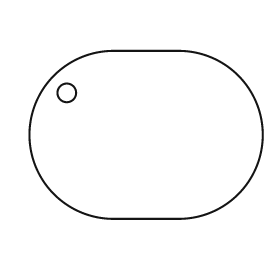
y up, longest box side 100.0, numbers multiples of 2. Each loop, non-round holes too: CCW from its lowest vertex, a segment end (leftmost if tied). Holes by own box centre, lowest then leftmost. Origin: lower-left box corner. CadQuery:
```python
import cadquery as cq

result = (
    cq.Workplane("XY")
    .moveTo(36.0, 0.0)
    .lineTo(64.0, 0.0)
    .threePointArc((100.0, 36.0), (64.0, 72.0))
    .lineTo(36.0, 72.0)
    .threePointArc((0.0, 36.0), (36.0, 0.0))
    .close()
    .moveTo(16.0, 54.0)
    .circle(4.0)
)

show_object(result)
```